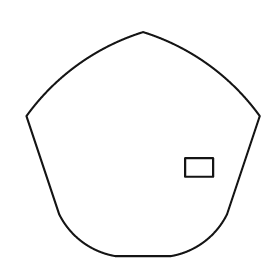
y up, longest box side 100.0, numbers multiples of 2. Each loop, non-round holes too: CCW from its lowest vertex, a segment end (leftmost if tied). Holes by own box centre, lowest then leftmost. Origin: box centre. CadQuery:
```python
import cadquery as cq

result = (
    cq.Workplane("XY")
    .moveTo(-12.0, -48.0)
    .lineTo(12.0, -48.0)
    .threePointArc((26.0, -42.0), (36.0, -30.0))
    .lineTo(50.0, 12.0)
    .threePointArc((28.0, 34.0), (0.0, 48.0))
    .threePointArc((-28.0, 34.0), (-50.0, 12.0))
    .lineTo(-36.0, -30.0)
    .threePointArc((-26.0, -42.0), (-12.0, -48.0))
    .close()
    .moveTo(18.0, -14.0)
    .lineTo(30.0, -14.0)
    .lineTo(30.0, -6.0)
    .lineTo(18.0, -6.0)
    .close()
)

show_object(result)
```